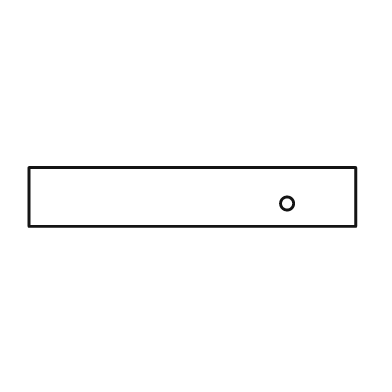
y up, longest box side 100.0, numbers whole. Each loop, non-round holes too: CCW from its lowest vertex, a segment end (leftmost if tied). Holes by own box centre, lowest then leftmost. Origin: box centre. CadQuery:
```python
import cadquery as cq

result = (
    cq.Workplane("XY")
    .moveTo(-50.0, -9.0)
    .lineTo(50.0, -9.0)
    .lineTo(50.0, 9.0)
    .lineTo(-50.0, 9.0)
    .close()
    .moveTo(29.0, -2.0)
    .circle(2.0)
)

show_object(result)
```